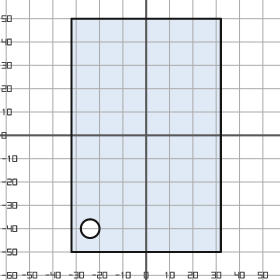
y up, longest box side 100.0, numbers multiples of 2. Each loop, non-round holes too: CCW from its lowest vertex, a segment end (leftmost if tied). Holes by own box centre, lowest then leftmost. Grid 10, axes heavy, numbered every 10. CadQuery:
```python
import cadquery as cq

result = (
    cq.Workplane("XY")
    .moveTo(-32.0, -50.0)
    .lineTo(32.0, -50.0)
    .lineTo(32.0, 50.0)
    .lineTo(-32.0, 50.0)
    .close()
    .moveTo(-24.0, -40.0)
    .circle(4.0)
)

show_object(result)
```